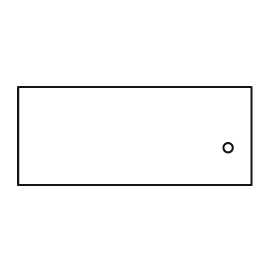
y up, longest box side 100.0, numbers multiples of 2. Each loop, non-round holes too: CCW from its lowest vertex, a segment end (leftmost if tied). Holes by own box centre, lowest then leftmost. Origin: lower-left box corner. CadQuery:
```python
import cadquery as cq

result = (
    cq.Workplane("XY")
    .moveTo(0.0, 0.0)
    .lineTo(100.0, 0.0)
    .lineTo(100.0, 42.0)
    .lineTo(0.0, 42.0)
    .close()
    .moveTo(90.0, 16.0)
    .circle(2.0)
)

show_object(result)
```